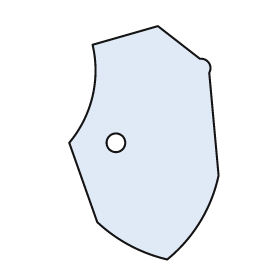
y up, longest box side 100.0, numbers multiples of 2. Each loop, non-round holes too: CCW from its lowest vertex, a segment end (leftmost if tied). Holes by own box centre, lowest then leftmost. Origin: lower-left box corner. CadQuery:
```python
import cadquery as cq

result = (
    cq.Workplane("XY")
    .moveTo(42.0, 0.0)
    .threePointArc((56.0, 16.0), (64.0, 36.0))
    .lineTo(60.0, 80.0)
    .threePointArc((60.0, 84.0), (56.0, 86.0))
    .lineTo(38.0, 100.0)
    .lineTo(10.0, 92.0)
    .threePointArc((10.0, 70.0), (0.0, 50.0))
    .lineTo(12.0, 16.0)
    .threePointArc((26.0, 6.0), (42.0, 0.0))
    .close()
    .moveTo(20.0, 50.0)
    .circle(4.0)
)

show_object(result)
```